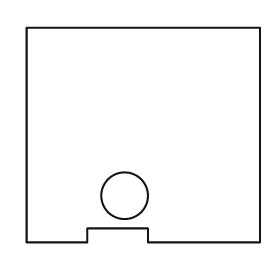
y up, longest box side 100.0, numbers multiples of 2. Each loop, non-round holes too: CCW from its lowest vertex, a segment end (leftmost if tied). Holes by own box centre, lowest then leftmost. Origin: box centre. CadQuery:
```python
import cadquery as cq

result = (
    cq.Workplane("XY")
    .moveTo(-50.0, -46.0)
    .lineTo(-24.0, -46.0)
    .lineTo(-24.0, -40.0)
    .lineTo(2.0, -40.0)
    .lineTo(2.0, -46.0)
    .lineTo(50.0, -46.0)
    .lineTo(50.0, 46.0)
    .lineTo(-50.0, 46.0)
    .close()
    .moveTo(-8.0, -26.0)
    .circle(10.0)
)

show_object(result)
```